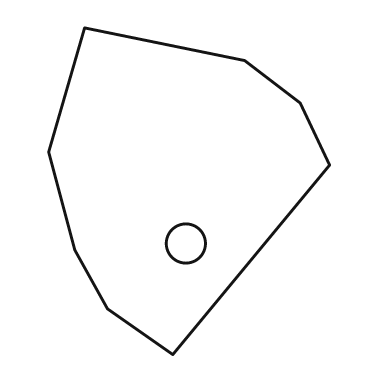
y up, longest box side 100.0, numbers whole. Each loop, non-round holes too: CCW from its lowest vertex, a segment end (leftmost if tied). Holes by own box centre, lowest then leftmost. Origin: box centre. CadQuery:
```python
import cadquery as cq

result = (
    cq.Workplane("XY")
    .moveTo(-5.0, -50.0)
    .lineTo(43.0, 8.0)
    .lineTo(34.0, 27.0)
    .lineTo(17.0, 40.0)
    .lineTo(-32.0, 50.0)
    .lineTo(-43.0, 12.0)
    .lineTo(-35.0, -18.0)
    .lineTo(-25.0, -36.0)
    .close()
    .moveTo(-1.0, -16.0)
    .circle(6.0)
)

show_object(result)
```